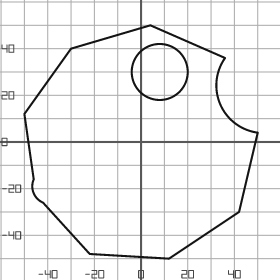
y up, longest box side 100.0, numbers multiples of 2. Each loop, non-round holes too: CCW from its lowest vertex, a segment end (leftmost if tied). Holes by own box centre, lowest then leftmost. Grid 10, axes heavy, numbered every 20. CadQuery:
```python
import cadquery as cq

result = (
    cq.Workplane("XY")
    .moveTo(12.0, -50.0)
    .lineTo(42.0, -30.0)
    .lineTo(50.0, 4.0)
    .threePointArc((34.0, 16.0), (36.0, 36.0))
    .lineTo(4.0, 50.0)
    .lineTo(-30.0, 40.0)
    .lineTo(-50.0, 12.0)
    .lineTo(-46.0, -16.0)
    .threePointArc((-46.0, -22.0), (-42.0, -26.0))
    .lineTo(-22.0, -48.0)
    .close()
    .moveTo(8.0, 30.0)
    .circle(12.0)
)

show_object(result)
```